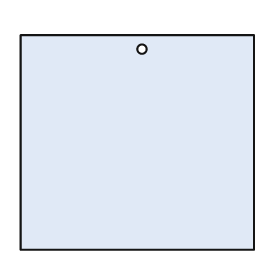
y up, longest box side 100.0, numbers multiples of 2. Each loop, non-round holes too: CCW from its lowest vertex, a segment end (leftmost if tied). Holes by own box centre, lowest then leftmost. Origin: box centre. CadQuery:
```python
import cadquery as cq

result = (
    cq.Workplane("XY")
    .moveTo(-50.0, -46.0)
    .lineTo(50.0, -46.0)
    .lineTo(50.0, 46.0)
    .lineTo(-50.0, 46.0)
    .close()
    .moveTo(2.0, 40.0)
    .circle(2.0)
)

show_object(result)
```